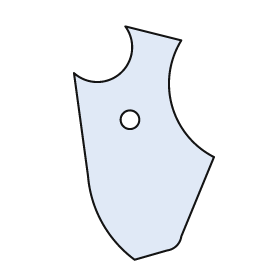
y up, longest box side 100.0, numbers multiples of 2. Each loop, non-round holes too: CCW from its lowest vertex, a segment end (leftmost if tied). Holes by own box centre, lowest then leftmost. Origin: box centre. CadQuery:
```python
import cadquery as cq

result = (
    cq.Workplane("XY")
    .moveTo(-4.0, -50.0)
    .lineTo(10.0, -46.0)
    .threePointArc((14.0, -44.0), (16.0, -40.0))
    .lineTo(30.0, -6.0)
    .threePointArc((12.0, 16.0), (16.0, 44.0))
    .lineTo(-8.0, 50.0)
    .threePointArc((-10.0, 30.0), (-30.0, 30.0))
    .lineTo(-24.0, -14.0)
    .threePointArc((-18.0, -34.0), (-4.0, -50.0))
    .close()
    .moveTo(-6.0, 10.0)
    .circle(4.0)
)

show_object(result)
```